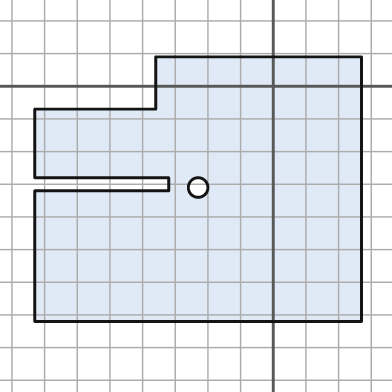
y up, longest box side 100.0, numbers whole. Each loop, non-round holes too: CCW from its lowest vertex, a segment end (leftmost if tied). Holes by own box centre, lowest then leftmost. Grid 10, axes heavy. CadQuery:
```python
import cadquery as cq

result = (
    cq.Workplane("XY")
    .moveTo(-73.0, -72.0)
    .lineTo(27.0, -72.0)
    .lineTo(27.0, 9.0)
    .lineTo(-36.0, 9.0)
    .lineTo(-36.0, -7.0)
    .lineTo(-73.0, -7.0)
    .lineTo(-73.0, -28.0)
    .lineTo(-32.0, -28.0)
    .lineTo(-32.0, -32.0)
    .lineTo(-73.0, -32.0)
    .close()
    .moveTo(-23.0, -31.0)
    .circle(3.0)
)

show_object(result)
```